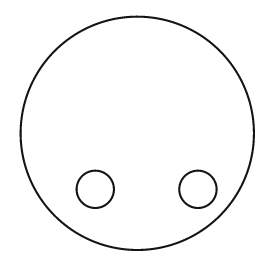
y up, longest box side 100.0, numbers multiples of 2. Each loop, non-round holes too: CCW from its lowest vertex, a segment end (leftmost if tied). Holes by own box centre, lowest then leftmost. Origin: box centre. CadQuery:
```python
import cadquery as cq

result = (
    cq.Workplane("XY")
    .moveTo(0.0, 0.0)
    .circle(50.0)
    .moveTo(-18.0, -24.0)
    .circle(8.0)
    .moveTo(26.0, -24.0)
    .circle(8.0)
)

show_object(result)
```